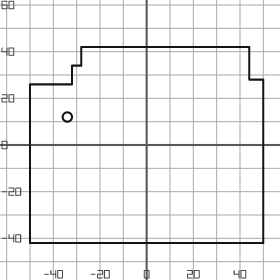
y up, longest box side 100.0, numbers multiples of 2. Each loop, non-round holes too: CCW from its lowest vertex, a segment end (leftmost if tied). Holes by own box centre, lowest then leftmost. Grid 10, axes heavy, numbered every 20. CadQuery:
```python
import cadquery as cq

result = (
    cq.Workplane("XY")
    .moveTo(-50.0, -42.0)
    .lineTo(50.0, -42.0)
    .lineTo(50.0, 28.0)
    .lineTo(44.0, 28.0)
    .lineTo(44.0, 42.0)
    .lineTo(-28.0, 42.0)
    .lineTo(-28.0, 34.0)
    .lineTo(-32.0, 34.0)
    .lineTo(-32.0, 26.0)
    .lineTo(-50.0, 26.0)
    .close()
    .moveTo(-34.0, 12.0)
    .circle(2.0)
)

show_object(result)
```